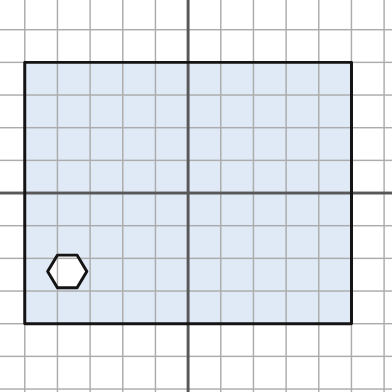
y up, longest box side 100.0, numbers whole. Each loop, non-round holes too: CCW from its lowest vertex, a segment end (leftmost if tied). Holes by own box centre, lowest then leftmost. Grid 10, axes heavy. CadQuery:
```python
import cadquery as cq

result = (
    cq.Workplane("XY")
    .moveTo(-50.0, -40.0)
    .lineTo(50.0, -40.0)
    .lineTo(50.0, 40.0)
    .lineTo(-50.0, 40.0)
    .close()
    .moveTo(-40.0, -29.0)
    .lineTo(-34.0, -29.0)
    .lineTo(-31.0, -24.0)
    .lineTo(-34.0, -19.0)
    .lineTo(-40.0, -19.0)
    .lineTo(-43.0, -24.0)
    .close()
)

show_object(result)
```